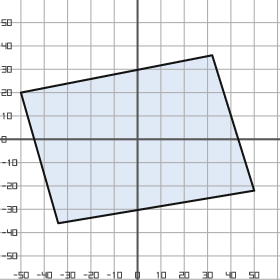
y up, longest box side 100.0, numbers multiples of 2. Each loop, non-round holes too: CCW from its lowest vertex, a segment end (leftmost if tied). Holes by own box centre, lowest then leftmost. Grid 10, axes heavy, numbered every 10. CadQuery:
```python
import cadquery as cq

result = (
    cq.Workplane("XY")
    .moveTo(-34.0, -36.0)
    .lineTo(50.0, -22.0)
    .lineTo(32.0, 36.0)
    .lineTo(-50.0, 20.0)
    .close()
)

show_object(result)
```